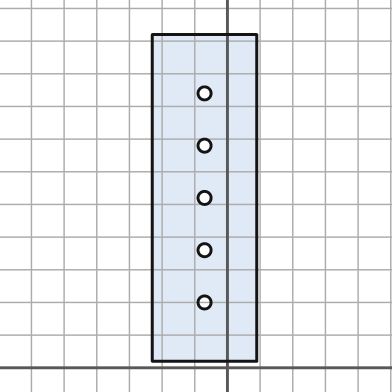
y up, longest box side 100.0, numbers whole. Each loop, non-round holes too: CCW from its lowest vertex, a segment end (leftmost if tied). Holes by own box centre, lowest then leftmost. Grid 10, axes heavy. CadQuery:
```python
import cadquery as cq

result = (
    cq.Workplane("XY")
    .moveTo(-23.0, 2.0)
    .lineTo(9.0, 2.0)
    .lineTo(9.0, 102.0)
    .lineTo(-23.0, 102.0)
    .close()
    .moveTo(-7.0, 20.0)
    .circle(2.0)
    .moveTo(-7.0, 36.0)
    .circle(2.0)
    .moveTo(-7.0, 52.0)
    .circle(2.0)
    .moveTo(-7.0, 68.0)
    .circle(2.0)
    .moveTo(-7.0, 84.0)
    .circle(2.0)
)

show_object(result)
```